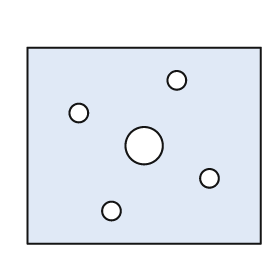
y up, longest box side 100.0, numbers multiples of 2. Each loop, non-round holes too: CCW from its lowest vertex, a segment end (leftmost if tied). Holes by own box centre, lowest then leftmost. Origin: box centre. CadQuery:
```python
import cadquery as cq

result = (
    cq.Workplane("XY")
    .moveTo(-50.0, -42.0)
    .lineTo(50.0, -42.0)
    .lineTo(50.0, 42.0)
    .lineTo(-50.0, 42.0)
    .close()
    .moveTo(-14.0, -28.0)
    .circle(4.0)
    .moveTo(28.0, -14.0)
    .circle(4.0)
    .moveTo(0.0, 0.0)
    .circle(8.0)
    .moveTo(-28.0, 14.0)
    .circle(4.0)
    .moveTo(14.0, 28.0)
    .circle(4.0)
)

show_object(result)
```